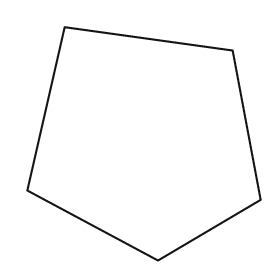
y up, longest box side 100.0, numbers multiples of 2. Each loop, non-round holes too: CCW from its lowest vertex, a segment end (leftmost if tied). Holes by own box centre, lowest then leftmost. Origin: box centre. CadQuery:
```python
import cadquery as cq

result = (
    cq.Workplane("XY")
    .moveTo(6.0, -50.0)
    .lineTo(50.0, -24.0)
    .lineTo(38.0, 40.0)
    .lineTo(-34.0, 50.0)
    .lineTo(-50.0, -20.0)
    .close()
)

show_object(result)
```